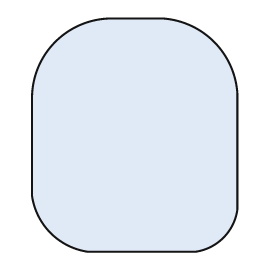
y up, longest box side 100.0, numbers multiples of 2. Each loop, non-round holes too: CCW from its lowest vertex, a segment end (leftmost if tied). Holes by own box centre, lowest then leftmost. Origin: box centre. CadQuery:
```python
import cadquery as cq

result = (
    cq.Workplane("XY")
    .moveTo(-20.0, -50.0)
    .lineTo(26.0, -50.0)
    .threePointArc((38.0, -44.0), (44.0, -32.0))
    .lineTo(44.0, 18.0)
    .threePointArc((34.0, 40.0), (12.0, 50.0))
    .lineTo(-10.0, 50.0)
    .threePointArc((-34.0, 40.0), (-44.0, 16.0))
    .lineTo(-44.0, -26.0)
    .threePointArc((-36.0, -42.0), (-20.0, -50.0))
    .close()
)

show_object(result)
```